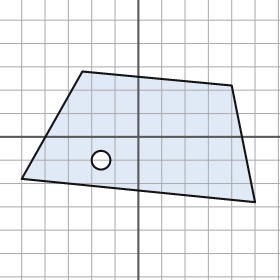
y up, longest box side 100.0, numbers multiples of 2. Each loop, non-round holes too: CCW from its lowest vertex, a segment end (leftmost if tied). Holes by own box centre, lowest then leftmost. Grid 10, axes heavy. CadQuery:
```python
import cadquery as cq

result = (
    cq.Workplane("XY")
    .moveTo(50.0, -28.0)
    .lineTo(40.0, 22.0)
    .lineTo(-24.0, 28.0)
    .lineTo(-50.0, -18.0)
    .close()
    .moveTo(-16.0, -10.0)
    .circle(4.0)
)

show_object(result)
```